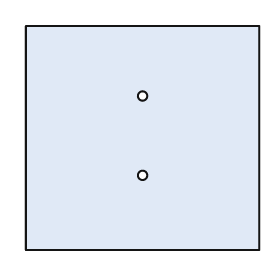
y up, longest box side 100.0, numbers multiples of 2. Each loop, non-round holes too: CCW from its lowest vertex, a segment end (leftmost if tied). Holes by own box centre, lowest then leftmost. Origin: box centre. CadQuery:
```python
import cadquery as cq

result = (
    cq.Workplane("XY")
    .moveTo(-50.0, -48.0)
    .lineTo(50.0, -48.0)
    .lineTo(50.0, 48.0)
    .lineTo(-50.0, 48.0)
    .close()
    .moveTo(0.0, -16.0)
    .circle(2.0)
    .moveTo(0.0, 18.0)
    .circle(2.0)
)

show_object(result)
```